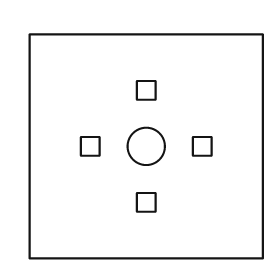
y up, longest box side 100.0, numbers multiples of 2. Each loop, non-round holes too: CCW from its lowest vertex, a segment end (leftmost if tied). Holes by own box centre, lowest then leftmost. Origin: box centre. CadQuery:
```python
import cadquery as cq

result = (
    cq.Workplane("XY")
    .moveTo(-50.0, -48.0)
    .lineTo(50.0, -48.0)
    .lineTo(50.0, 48.0)
    .lineTo(-50.0, 48.0)
    .close()
    .moveTo(-4.0, -28.0)
    .lineTo(4.0, -28.0)
    .lineTo(4.0, -20.0)
    .lineTo(-4.0, -20.0)
    .close()
    .moveTo(-28.0, -4.0)
    .lineTo(-20.0, -4.0)
    .lineTo(-20.0, 4.0)
    .lineTo(-28.0, 4.0)
    .close()
    .moveTo(0.0, 0.0)
    .circle(8.0)
    .moveTo(20.0, -4.0)
    .lineTo(28.0, -4.0)
    .lineTo(28.0, 4.0)
    .lineTo(20.0, 4.0)
    .close()
    .moveTo(-4.0, 20.0)
    .lineTo(4.0, 20.0)
    .lineTo(4.0, 28.0)
    .lineTo(-4.0, 28.0)
    .close()
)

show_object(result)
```